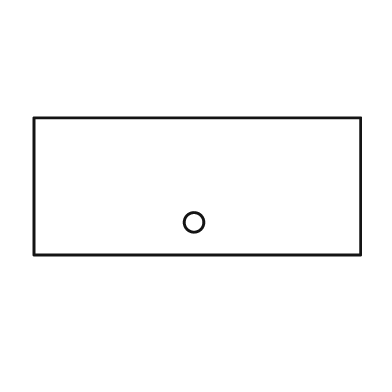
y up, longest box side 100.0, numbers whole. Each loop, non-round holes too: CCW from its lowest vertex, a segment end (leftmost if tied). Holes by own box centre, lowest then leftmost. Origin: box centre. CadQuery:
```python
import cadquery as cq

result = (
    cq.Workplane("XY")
    .moveTo(-50.0, -21.0)
    .lineTo(50.0, -21.0)
    .lineTo(50.0, 21.0)
    .lineTo(-50.0, 21.0)
    .close()
    .moveTo(-1.0, -11.0)
    .circle(3.0)
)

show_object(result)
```